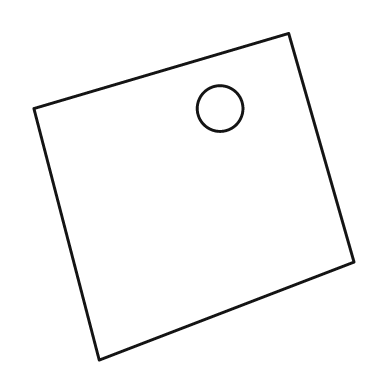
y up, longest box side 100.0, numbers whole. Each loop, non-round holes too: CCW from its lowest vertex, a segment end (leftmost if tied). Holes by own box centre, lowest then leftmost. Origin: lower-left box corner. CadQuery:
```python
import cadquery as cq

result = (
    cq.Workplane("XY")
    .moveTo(20.0, 0.0)
    .lineTo(98.0, 30.0)
    .lineTo(78.0, 100.0)
    .lineTo(0.0, 77.0)
    .close()
    .moveTo(57.0, 77.0)
    .circle(7.0)
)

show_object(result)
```